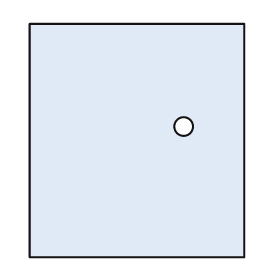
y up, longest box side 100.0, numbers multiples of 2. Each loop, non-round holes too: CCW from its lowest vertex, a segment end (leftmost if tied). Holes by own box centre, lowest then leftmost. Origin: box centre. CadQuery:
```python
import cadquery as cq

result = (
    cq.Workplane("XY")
    .moveTo(-46.0, -50.0)
    .lineTo(46.0, -50.0)
    .lineTo(46.0, 50.0)
    .lineTo(-46.0, 50.0)
    .close()
    .moveTo(20.0, 6.0)
    .circle(4.0)
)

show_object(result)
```